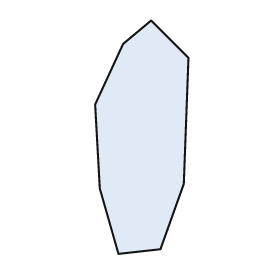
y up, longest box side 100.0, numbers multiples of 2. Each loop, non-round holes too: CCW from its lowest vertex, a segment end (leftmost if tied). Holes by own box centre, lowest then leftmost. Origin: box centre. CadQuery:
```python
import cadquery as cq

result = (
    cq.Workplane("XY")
    .moveTo(-10.0, -50.0)
    .lineTo(8.0, -48.0)
    .lineTo(18.0, -20.0)
    .lineTo(20.0, 34.0)
    .lineTo(4.0, 50.0)
    .lineTo(-8.0, 40.0)
    .lineTo(-20.0, 14.0)
    .lineTo(-18.0, -22.0)
    .close()
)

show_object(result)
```